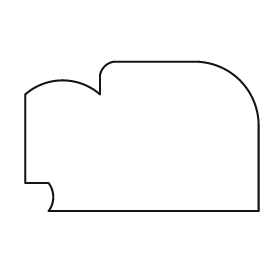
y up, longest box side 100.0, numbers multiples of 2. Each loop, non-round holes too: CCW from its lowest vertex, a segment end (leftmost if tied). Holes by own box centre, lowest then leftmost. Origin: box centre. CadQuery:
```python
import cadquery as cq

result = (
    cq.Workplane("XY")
    .moveTo(-40.0, -32.0)
    .lineTo(50.0, -32.0)
    .lineTo(50.0, 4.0)
    .threePointArc((42.0, 24.0), (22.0, 32.0))
    .lineTo(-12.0, 32.0)
    .threePointArc((-16.0, 30.0), (-18.0, 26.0))
    .lineTo(-18.0, 18.0)
    .threePointArc((-34.0, 24.0), (-50.0, 18.0))
    .lineTo(-50.0, -20.0)
    .lineTo(-40.0, -20.0)
    .threePointArc((-38.0, -26.0), (-40.0, -32.0))
    .close()
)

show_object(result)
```